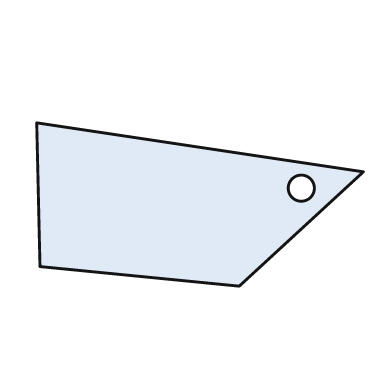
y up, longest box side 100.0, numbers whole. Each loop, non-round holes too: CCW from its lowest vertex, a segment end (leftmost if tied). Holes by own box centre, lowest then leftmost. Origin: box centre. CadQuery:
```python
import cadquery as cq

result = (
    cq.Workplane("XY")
    .moveTo(12.0, -25.0)
    .lineTo(50.0, 10.0)
    .lineTo(-50.0, 25.0)
    .lineTo(-49.0, -19.0)
    .close()
    .moveTo(31.0, 5.0)
    .circle(4.0)
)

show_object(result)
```